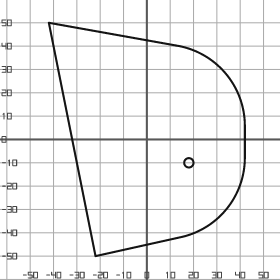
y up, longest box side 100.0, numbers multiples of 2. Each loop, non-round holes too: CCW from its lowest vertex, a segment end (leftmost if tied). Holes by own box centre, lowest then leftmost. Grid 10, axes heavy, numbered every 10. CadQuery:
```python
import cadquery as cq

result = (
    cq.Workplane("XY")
    .moveTo(-22.0, -50.0)
    .lineTo(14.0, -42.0)
    .threePointArc((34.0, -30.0), (42.0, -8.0))
    .lineTo(42.0, 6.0)
    .threePointArc((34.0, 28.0), (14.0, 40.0))
    .lineTo(-42.0, 50.0)
    .close()
    .moveTo(18.0, -10.0)
    .circle(2.0)
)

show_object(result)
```